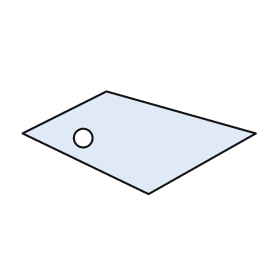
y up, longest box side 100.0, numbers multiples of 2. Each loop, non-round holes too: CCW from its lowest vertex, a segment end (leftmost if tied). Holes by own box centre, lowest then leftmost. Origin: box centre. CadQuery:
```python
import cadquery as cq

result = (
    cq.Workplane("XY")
    .moveTo(4.0, -22.0)
    .lineTo(50.0, 4.0)
    .lineTo(-14.0, 22.0)
    .lineTo(-50.0, 4.0)
    .close()
    .moveTo(-24.0, 2.0)
    .circle(4.0)
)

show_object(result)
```